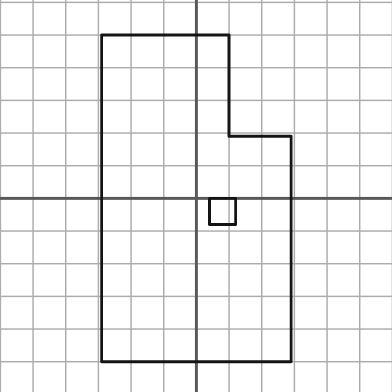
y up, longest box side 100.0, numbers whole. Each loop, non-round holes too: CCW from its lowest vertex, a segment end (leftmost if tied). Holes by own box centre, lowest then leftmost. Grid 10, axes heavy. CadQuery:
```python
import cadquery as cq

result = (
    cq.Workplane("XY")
    .moveTo(-29.0, -50.0)
    .lineTo(29.0, -50.0)
    .lineTo(29.0, 19.0)
    .lineTo(10.0, 19.0)
    .lineTo(10.0, 50.0)
    .lineTo(-29.0, 50.0)
    .close()
    .moveTo(4.0, -8.0)
    .lineTo(12.0, -8.0)
    .lineTo(12.0, 0.0)
    .lineTo(4.0, 0.0)
    .close()
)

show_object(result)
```